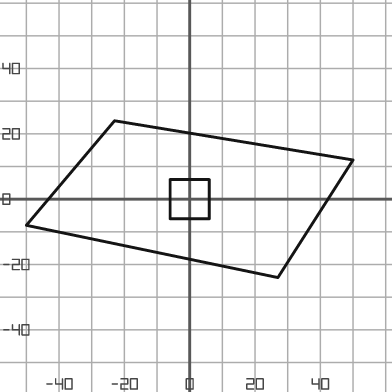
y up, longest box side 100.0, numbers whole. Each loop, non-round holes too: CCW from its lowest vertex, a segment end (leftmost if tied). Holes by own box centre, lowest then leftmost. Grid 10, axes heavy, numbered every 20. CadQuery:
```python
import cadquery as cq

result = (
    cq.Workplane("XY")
    .moveTo(27.0, -24.0)
    .lineTo(50.0, 12.0)
    .lineTo(-23.0, 24.0)
    .lineTo(-50.0, -8.0)
    .close()
    .moveTo(-6.0, -6.0)
    .lineTo(6.0, -6.0)
    .lineTo(6.0, 6.0)
    .lineTo(-6.0, 6.0)
    .close()
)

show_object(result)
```